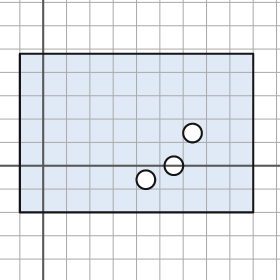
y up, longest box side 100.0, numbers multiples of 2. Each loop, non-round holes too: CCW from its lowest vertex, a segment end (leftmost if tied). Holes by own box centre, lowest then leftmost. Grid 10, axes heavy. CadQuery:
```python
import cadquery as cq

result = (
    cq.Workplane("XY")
    .moveTo(-10.0, -20.0)
    .lineTo(90.0, -20.0)
    .lineTo(90.0, 48.0)
    .lineTo(-10.0, 48.0)
    .close()
    .moveTo(44.0, -6.0)
    .circle(4.0)
    .moveTo(56.0, 0.0)
    .circle(4.0)
    .moveTo(64.0, 14.0)
    .circle(4.0)
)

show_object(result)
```